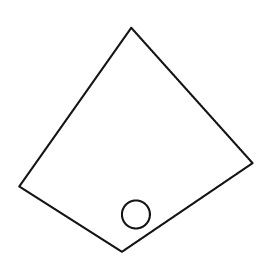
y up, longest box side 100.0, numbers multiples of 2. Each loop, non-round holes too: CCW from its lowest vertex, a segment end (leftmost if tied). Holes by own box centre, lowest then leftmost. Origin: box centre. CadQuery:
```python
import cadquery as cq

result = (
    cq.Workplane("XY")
    .moveTo(-6.0, -48.0)
    .lineTo(50.0, -10.0)
    .lineTo(-2.0, 48.0)
    .lineTo(-50.0, -20.0)
    .close()
    .moveTo(0.0, -32.0)
    .circle(6.0)
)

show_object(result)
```